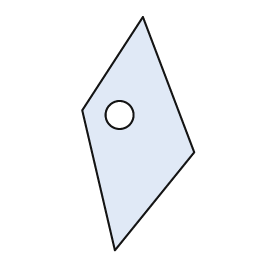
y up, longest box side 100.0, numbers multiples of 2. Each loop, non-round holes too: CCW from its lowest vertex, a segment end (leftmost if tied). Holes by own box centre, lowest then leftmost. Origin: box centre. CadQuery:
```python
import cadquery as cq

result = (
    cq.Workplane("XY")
    .moveTo(-10.0, -50.0)
    .lineTo(24.0, -8.0)
    .lineTo(2.0, 50.0)
    .lineTo(-24.0, 10.0)
    .close()
    .moveTo(-8.0, 8.0)
    .circle(6.0)
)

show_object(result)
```